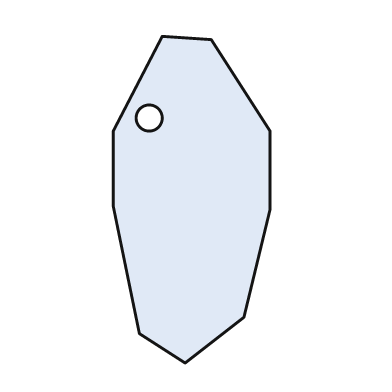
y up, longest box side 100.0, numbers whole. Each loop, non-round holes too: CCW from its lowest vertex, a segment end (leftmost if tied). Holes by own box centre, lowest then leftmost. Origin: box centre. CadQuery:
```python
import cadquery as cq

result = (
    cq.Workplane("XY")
    .moveTo(-2.0, -50.0)
    .lineTo(16.0, -36.0)
    .lineTo(24.0, -3.0)
    .lineTo(24.0, 21.0)
    .lineTo(6.0, 49.0)
    .lineTo(-9.0, 50.0)
    .lineTo(-24.0, 21.0)
    .lineTo(-24.0, -2.0)
    .lineTo(-16.0, -41.0)
    .close()
    .moveTo(-13.0, 25.0)
    .circle(4.0)
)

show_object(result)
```